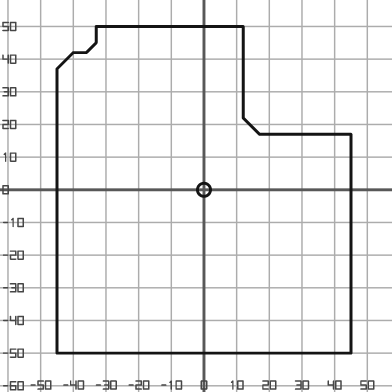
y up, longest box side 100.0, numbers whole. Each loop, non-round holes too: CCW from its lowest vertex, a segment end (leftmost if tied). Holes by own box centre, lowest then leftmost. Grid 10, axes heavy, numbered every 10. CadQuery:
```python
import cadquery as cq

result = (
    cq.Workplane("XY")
    .moveTo(-45.0, -50.0)
    .lineTo(45.0, -50.0)
    .lineTo(45.0, 17.0)
    .lineTo(17.0, 17.0)
    .lineTo(12.0, 22.0)
    .lineTo(12.0, 50.0)
    .lineTo(-33.0, 50.0)
    .lineTo(-33.0, 45.0)
    .lineTo(-36.0, 42.0)
    .lineTo(-40.0, 42.0)
    .lineTo(-45.0, 37.0)
    .close()
    .moveTo(0.0, 0.0)
    .circle(2.0)
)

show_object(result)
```